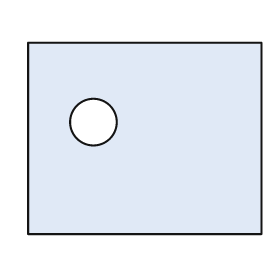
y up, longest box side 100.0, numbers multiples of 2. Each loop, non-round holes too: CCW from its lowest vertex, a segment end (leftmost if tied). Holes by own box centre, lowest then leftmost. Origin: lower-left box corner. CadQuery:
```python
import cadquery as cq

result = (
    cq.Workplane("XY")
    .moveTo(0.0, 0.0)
    .lineTo(100.0, 0.0)
    .lineTo(100.0, 82.0)
    .lineTo(0.0, 82.0)
    .close()
    .moveTo(28.0, 48.0)
    .circle(10.0)
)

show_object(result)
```